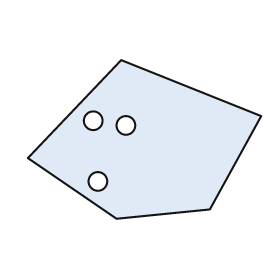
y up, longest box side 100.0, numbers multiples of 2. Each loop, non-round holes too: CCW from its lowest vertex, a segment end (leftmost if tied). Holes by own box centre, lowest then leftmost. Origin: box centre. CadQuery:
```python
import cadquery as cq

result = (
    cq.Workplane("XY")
    .moveTo(-12.0, -34.0)
    .lineTo(28.0, -30.0)
    .lineTo(50.0, 10.0)
    .lineTo(-10.0, 34.0)
    .lineTo(-50.0, -8.0)
    .close()
    .moveTo(-20.0, -18.0)
    .circle(4.0)
    .moveTo(-8.0, 6.0)
    .circle(4.0)
    .moveTo(-22.0, 8.0)
    .circle(4.0)
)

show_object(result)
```